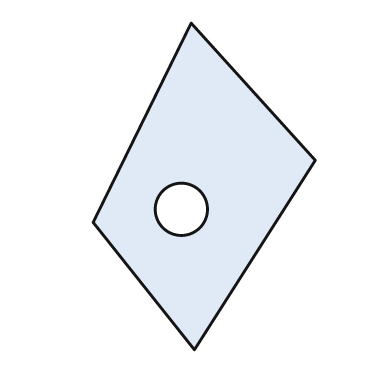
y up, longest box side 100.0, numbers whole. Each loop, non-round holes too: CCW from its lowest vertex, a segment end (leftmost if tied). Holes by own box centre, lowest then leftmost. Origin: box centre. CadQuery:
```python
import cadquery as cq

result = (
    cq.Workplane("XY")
    .moveTo(-3.0, -50.0)
    .lineTo(34.0, 8.0)
    .lineTo(-4.0, 50.0)
    .lineTo(-34.0, -11.0)
    .close()
    .moveTo(-7.0, -7.0)
    .circle(8.0)
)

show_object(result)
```